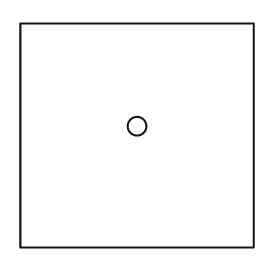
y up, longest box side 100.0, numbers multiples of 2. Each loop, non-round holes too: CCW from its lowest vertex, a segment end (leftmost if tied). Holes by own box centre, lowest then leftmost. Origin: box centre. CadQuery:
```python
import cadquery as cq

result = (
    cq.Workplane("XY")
    .moveTo(-50.0, -48.0)
    .lineTo(50.0, -48.0)
    .lineTo(50.0, 48.0)
    .lineTo(-50.0, 48.0)
    .close()
    .moveTo(0.0, 4.0)
    .circle(4.0)
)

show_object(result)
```